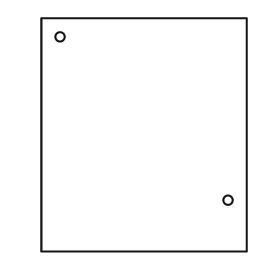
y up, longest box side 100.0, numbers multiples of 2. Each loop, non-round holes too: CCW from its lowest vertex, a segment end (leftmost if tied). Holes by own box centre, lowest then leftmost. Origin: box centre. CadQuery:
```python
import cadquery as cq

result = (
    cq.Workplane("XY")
    .moveTo(-44.0, -50.0)
    .lineTo(44.0, -50.0)
    .lineTo(44.0, 50.0)
    .lineTo(-44.0, 50.0)
    .close()
    .moveTo(36.0, -28.0)
    .circle(2.0)
    .moveTo(-36.0, 42.0)
    .circle(2.0)
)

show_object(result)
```